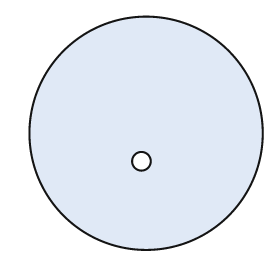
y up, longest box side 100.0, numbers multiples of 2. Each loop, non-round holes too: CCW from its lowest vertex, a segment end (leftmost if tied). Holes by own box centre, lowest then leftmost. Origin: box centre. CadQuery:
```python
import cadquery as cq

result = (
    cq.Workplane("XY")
    .moveTo(0.0, 0.0)
    .circle(50.0)
    .moveTo(-2.0, -12.0)
    .circle(4.0)
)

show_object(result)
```